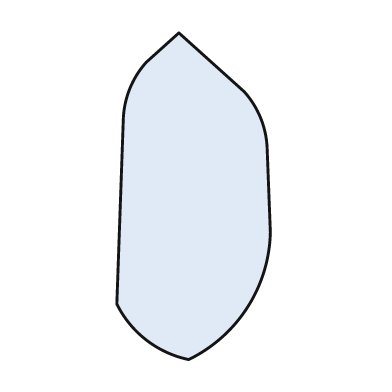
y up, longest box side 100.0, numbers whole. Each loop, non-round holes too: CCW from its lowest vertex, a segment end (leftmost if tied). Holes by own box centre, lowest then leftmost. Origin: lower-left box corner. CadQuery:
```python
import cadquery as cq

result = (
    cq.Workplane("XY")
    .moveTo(22.0, 0.0)
    .threePointArc((40.0, 16.0), (47.0, 39.0))
    .lineTo(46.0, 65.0)
    .threePointArc((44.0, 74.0), (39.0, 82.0))
    .lineTo(19.0, 100.0)
    .lineTo(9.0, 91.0)
    .threePointArc((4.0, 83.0), (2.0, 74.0))
    .lineTo(0.0, 17.0)
    .threePointArc((9.0, 6.0), (22.0, 0.0))
    .close()
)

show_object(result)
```